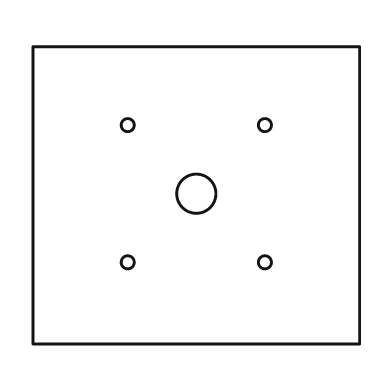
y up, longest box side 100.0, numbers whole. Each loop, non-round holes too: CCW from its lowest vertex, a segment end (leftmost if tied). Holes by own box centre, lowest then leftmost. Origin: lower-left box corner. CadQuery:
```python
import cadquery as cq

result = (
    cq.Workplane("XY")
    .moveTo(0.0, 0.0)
    .lineTo(100.0, 0.0)
    .lineTo(100.0, 91.0)
    .lineTo(0.0, 91.0)
    .close()
    .moveTo(29.0, 25.0)
    .circle(2.0)
    .moveTo(71.0, 25.0)
    .circle(2.0)
    .moveTo(50.0, 46.0)
    .circle(6.0)
    .moveTo(29.0, 67.0)
    .circle(2.0)
    .moveTo(71.0, 67.0)
    .circle(2.0)
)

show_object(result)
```